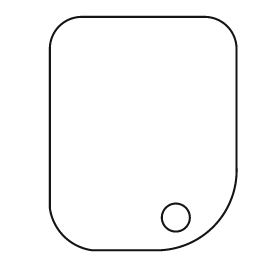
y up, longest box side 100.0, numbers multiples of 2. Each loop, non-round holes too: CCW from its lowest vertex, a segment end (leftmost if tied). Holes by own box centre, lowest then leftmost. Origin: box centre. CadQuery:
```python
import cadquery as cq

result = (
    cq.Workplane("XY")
    .moveTo(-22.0, -50.0)
    .lineTo(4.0, -50.0)
    .threePointArc((30.0, -40.0), (40.0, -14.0))
    .lineTo(40.0, 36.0)
    .threePointArc((36.0, 46.0), (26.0, 50.0))
    .lineTo(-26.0, 50.0)
    .threePointArc((-36.0, 46.0), (-40.0, 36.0))
    .lineTo(-40.0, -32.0)
    .threePointArc((-34.0, -44.0), (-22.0, -50.0))
    .close()
    .moveTo(14.0, -36.0)
    .circle(6.0)
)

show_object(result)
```